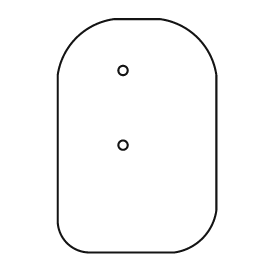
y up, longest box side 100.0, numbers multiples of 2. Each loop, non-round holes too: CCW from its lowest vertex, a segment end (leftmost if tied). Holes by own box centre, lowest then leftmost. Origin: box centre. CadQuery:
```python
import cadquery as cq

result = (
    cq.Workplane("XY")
    .moveTo(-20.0, -50.0)
    .lineTo(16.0, -50.0)
    .threePointArc((28.0, -44.0), (34.0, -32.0))
    .lineTo(34.0, 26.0)
    .threePointArc((26.0, 42.0), (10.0, 50.0))
    .lineTo(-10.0, 50.0)
    .threePointArc((-26.0, 42.0), (-34.0, 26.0))
    .lineTo(-34.0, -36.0)
    .threePointArc((-30.0, -46.0), (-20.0, -50.0))
    .close()
    .moveTo(-6.0, -4.0)
    .circle(2.0)
    .moveTo(-6.0, 28.0)
    .circle(2.0)
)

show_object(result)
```